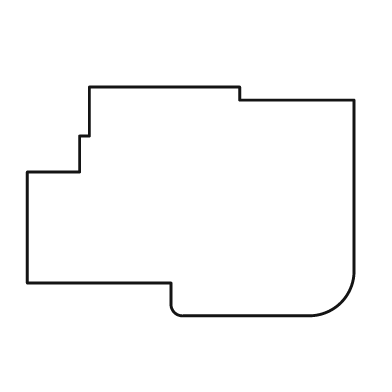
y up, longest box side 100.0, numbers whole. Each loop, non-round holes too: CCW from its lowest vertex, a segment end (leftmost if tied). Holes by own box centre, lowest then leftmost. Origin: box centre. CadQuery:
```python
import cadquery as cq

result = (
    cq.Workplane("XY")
    .moveTo(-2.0, -35.0)
    .lineTo(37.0, -35.0)
    .threePointArc((46.0, -31.0), (50.0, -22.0))
    .lineTo(50.0, 31.0)
    .lineTo(15.0, 31.0)
    .lineTo(15.0, 35.0)
    .lineTo(-31.0, 35.0)
    .lineTo(-31.0, 20.0)
    .lineTo(-34.0, 20.0)
    .lineTo(-34.0, 9.0)
    .lineTo(-50.0, 9.0)
    .lineTo(-50.0, -25.0)
    .lineTo(-6.0, -25.0)
    .lineTo(-6.0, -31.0)
    .threePointArc((-5.0, -34.0), (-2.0, -35.0))
    .close()
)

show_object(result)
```